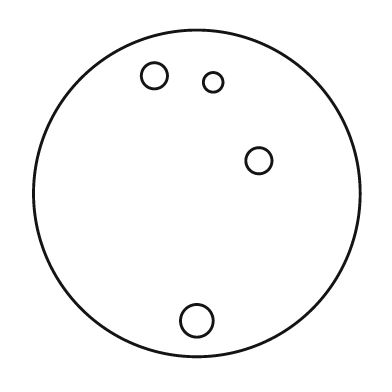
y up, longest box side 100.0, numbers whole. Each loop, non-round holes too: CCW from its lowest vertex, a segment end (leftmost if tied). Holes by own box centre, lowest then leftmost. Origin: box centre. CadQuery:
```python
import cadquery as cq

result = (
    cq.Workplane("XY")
    .moveTo(0.0, 0.0)
    .circle(50.0)
    .moveTo(0.0, -39.0)
    .circle(5.0)
    .moveTo(19.0, 10.0)
    .circle(4.0)
    .moveTo(5.0, 34.0)
    .circle(3.0)
    .moveTo(-13.0, 36.0)
    .circle(4.0)
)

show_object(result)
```